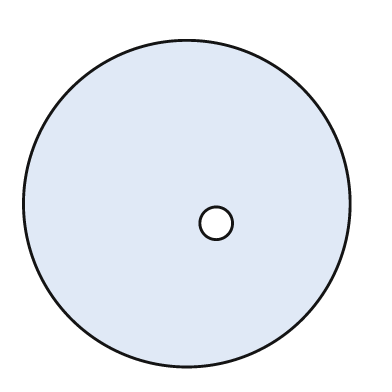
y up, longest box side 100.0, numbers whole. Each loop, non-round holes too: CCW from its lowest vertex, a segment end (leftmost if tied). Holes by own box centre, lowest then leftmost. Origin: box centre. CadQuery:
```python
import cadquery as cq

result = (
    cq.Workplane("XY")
    .moveTo(0.0, 0.0)
    .circle(50.0)
    .moveTo(9.0, -6.0)
    .circle(5.0)
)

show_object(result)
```